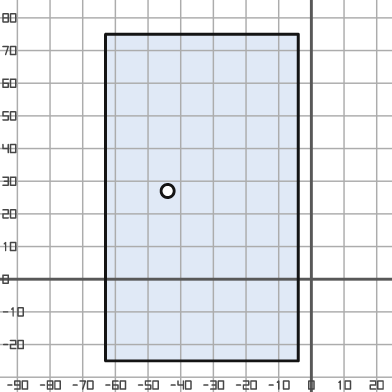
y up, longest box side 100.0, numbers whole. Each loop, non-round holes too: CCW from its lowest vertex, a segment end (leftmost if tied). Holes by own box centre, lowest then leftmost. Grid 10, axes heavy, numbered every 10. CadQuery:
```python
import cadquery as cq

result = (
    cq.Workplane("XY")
    .moveTo(-63.0, -25.0)
    .lineTo(-4.0, -25.0)
    .lineTo(-4.0, 75.0)
    .lineTo(-63.0, 75.0)
    .close()
    .moveTo(-44.0, 27.0)
    .circle(2.0)
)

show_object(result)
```